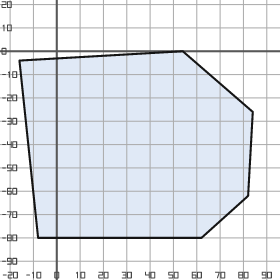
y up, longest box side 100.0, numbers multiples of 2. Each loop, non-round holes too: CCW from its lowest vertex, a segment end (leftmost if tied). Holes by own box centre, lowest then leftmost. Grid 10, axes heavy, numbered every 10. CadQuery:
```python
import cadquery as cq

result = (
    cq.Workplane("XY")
    .moveTo(-8.0, -80.0)
    .lineTo(62.0, -80.0)
    .lineTo(82.0, -62.0)
    .lineTo(84.0, -26.0)
    .lineTo(54.0, 0.0)
    .lineTo(-16.0, -4.0)
    .close()
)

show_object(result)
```